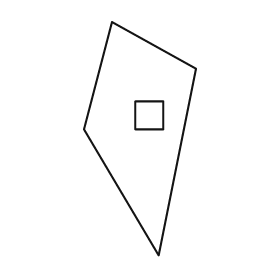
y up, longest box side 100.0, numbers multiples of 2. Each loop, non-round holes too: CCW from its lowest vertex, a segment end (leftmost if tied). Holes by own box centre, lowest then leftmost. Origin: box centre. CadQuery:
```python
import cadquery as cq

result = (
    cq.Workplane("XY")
    .moveTo(8.0, -50.0)
    .lineTo(24.0, 30.0)
    .lineTo(-12.0, 50.0)
    .lineTo(-24.0, 4.0)
    .close()
    .moveTo(-2.0, 4.0)
    .lineTo(10.0, 4.0)
    .lineTo(10.0, 16.0)
    .lineTo(-2.0, 16.0)
    .close()
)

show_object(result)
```